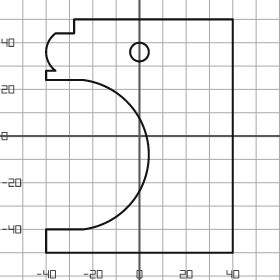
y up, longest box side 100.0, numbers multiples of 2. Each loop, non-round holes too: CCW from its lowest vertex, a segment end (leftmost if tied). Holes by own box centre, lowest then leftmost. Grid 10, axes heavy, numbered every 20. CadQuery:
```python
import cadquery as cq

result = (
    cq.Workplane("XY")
    .moveTo(-40.0, -50.0)
    .lineTo(40.0, -50.0)
    .lineTo(40.0, 50.0)
    .lineTo(-28.0, 50.0)
    .lineTo(-28.0, 44.0)
    .lineTo(-36.0, 44.0)
    .threePointArc((-40.0, 36.0), (-36.0, 28.0))
    .lineTo(-40.0, 28.0)
    .lineTo(-40.0, 24.0)
    .lineTo(-24.0, 24.0)
    .threePointArc((4.0, -8.0), (-24.0, -40.0))
    .lineTo(-40.0, -40.0)
    .close()
    .moveTo(0.0, 36.0)
    .circle(4.0)
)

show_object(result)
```